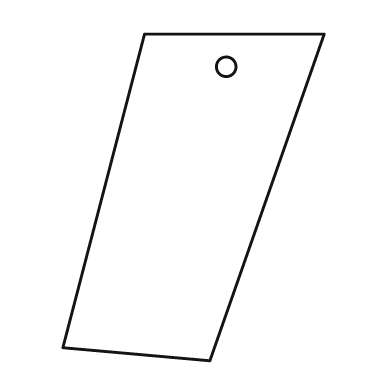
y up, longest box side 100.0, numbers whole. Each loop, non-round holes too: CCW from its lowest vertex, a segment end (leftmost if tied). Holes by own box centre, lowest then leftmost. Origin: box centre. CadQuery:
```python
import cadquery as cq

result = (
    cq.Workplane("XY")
    .moveTo(5.0, -50.0)
    .lineTo(40.0, 50.0)
    .lineTo(-15.0, 50.0)
    .lineTo(-40.0, -46.0)
    .close()
    .moveTo(10.0, 40.0)
    .circle(3.0)
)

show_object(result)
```